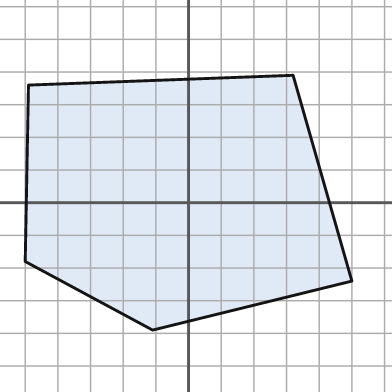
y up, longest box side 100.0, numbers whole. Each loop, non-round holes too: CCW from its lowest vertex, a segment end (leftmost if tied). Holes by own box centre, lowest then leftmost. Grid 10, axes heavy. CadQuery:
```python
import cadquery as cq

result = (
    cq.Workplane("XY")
    .moveTo(-11.0, -39.0)
    .lineTo(50.0, -24.0)
    .lineTo(32.0, 39.0)
    .lineTo(-49.0, 36.0)
    .lineTo(-50.0, -18.0)
    .close()
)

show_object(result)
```